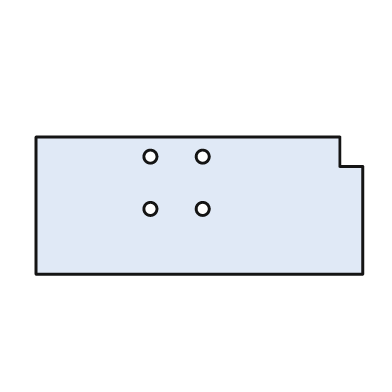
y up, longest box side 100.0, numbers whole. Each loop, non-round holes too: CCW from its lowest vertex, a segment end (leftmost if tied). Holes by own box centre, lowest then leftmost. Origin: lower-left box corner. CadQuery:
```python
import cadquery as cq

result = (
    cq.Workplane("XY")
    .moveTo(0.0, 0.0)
    .lineTo(100.0, 0.0)
    .lineTo(100.0, 33.0)
    .lineTo(93.0, 33.0)
    .lineTo(93.0, 42.0)
    .lineTo(0.0, 42.0)
    .close()
    .moveTo(35.0, 20.0)
    .circle(2.0)
    .moveTo(51.0, 20.0)
    .circle(2.0)
    .moveTo(35.0, 36.0)
    .circle(2.0)
    .moveTo(51.0, 36.0)
    .circle(2.0)
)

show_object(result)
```